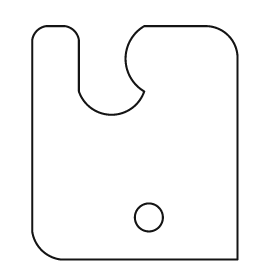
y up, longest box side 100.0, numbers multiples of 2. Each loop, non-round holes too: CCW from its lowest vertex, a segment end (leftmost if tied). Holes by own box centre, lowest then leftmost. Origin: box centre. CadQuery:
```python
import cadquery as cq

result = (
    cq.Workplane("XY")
    .moveTo(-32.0, -50.0)
    .lineTo(44.0, -50.0)
    .lineTo(44.0, 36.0)
    .threePointArc((40.0, 46.0), (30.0, 50.0))
    .lineTo(4.0, 50.0)
    .threePointArc((-4.0, 36.0), (4.0, 22.0))
    .threePointArc((-10.0, 12.0), (-24.0, 22.0))
    .lineTo(-24.0, 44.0)
    .threePointArc((-26.0, 48.0), (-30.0, 50.0))
    .lineTo(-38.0, 50.0)
    .threePointArc((-42.0, 48.0), (-44.0, 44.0))
    .lineTo(-44.0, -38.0)
    .threePointArc((-40.0, -46.0), (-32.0, -50.0))
    .close()
    .moveTo(6.0, -32.0)
    .circle(6.0)
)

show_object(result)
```